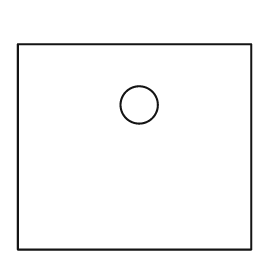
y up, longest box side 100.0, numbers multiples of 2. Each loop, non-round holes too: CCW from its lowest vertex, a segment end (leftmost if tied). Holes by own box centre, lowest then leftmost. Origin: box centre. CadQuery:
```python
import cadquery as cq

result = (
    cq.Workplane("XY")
    .moveTo(-50.0, -44.0)
    .lineTo(50.0, -44.0)
    .lineTo(50.0, 44.0)
    .lineTo(-50.0, 44.0)
    .close()
    .moveTo(2.0, 18.0)
    .circle(8.0)
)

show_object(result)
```